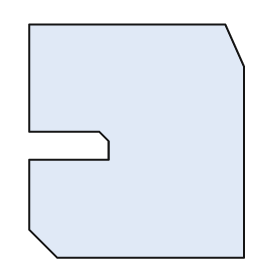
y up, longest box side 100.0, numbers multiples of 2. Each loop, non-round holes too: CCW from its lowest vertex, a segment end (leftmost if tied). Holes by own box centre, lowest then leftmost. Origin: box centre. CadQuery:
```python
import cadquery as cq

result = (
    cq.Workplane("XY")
    .moveTo(-34.0, -50.0)
    .lineTo(46.0, -50.0)
    .lineTo(46.0, 32.0)
    .lineTo(38.0, 50.0)
    .lineTo(-46.0, 50.0)
    .lineTo(-46.0, 4.0)
    .lineTo(-16.0, 4.0)
    .lineTo(-12.0, 0.0)
    .lineTo(-12.0, -8.0)
    .lineTo(-46.0, -8.0)
    .lineTo(-46.0, -38.0)
    .close()
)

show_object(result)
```